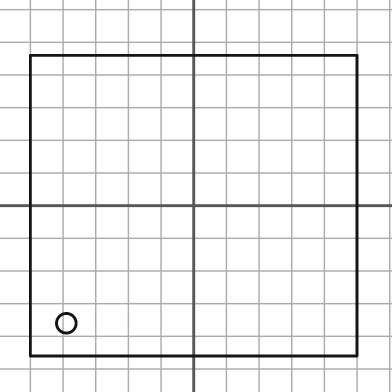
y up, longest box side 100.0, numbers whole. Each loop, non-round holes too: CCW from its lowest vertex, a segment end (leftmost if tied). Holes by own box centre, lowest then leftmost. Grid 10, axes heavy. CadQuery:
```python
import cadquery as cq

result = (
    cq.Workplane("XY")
    .moveTo(-50.0, -46.0)
    .lineTo(50.0, -46.0)
    .lineTo(50.0, 46.0)
    .lineTo(-50.0, 46.0)
    .close()
    .moveTo(-39.0, -36.0)
    .circle(3.0)
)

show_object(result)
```